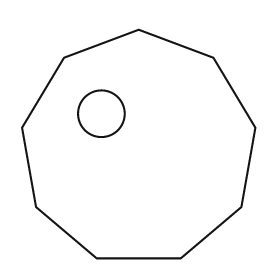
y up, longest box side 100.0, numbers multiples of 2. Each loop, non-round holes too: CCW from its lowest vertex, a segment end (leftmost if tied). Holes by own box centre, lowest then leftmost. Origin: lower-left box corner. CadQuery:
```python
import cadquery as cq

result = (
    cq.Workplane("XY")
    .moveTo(32.0, 0.0)
    .lineTo(68.0, 0.0)
    .lineTo(94.0, 22.0)
    .lineTo(100.0, 56.0)
    .lineTo(82.0, 86.0)
    .lineTo(50.0, 98.0)
    .lineTo(18.0, 86.0)
    .lineTo(0.0, 56.0)
    .lineTo(6.0, 22.0)
    .close()
    .moveTo(34.0, 62.0)
    .circle(10.0)
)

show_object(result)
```